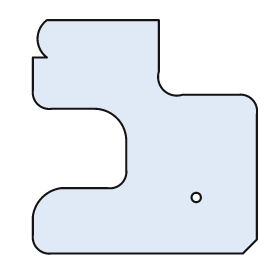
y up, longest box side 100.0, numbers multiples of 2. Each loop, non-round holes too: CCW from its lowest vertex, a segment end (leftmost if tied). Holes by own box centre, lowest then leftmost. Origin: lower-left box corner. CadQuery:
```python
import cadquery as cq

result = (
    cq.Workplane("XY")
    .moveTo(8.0, 0.0)
    .lineTo(90.0, 0.0)
    .lineTo(96.0, 6.0)
    .lineTo(96.0, 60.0)
    .threePointArc((94.0, 66.0), (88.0, 68.0))
    .lineTo(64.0, 68.0)
    .threePointArc((56.0, 70.0), (54.0, 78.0))
    .lineTo(54.0, 100.0)
    .lineTo(6.0, 100.0)
    .threePointArc((2.0, 92.0), (6.0, 84.0))
    .lineTo(0.0, 84.0)
    .lineTo(0.0, 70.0)
    .threePointArc((2.0, 64.0), (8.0, 62.0))
    .lineTo(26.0, 62.0)
    .threePointArc((36.0, 58.0), (40.0, 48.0))
    .lineTo(40.0, 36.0)
    .threePointArc((38.0, 30.0), (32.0, 28.0))
    .lineTo(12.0, 28.0)
    .threePointArc((4.0, 24.0), (0.0, 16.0))
    .lineTo(0.0, 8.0)
    .threePointArc((2.0, 2.0), (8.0, 0.0))
    .close()
    .moveTo(70.0, 24.0)
    .circle(2.0)
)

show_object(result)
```